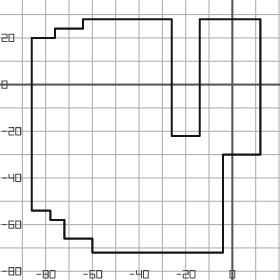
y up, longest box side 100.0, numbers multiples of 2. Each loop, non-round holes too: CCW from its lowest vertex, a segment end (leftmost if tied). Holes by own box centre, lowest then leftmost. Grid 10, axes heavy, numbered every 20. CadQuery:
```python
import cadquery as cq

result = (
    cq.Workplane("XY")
    .moveTo(-60.0, -72.0)
    .lineTo(-4.0, -72.0)
    .lineTo(-4.0, -30.0)
    .lineTo(12.0, -30.0)
    .lineTo(12.0, 28.0)
    .lineTo(-14.0, 28.0)
    .lineTo(-14.0, -22.0)
    .lineTo(-26.0, -22.0)
    .lineTo(-26.0, 28.0)
    .lineTo(-64.0, 28.0)
    .lineTo(-64.0, 24.0)
    .lineTo(-76.0, 24.0)
    .lineTo(-76.0, 20.0)
    .lineTo(-86.0, 20.0)
    .lineTo(-86.0, -54.0)
    .lineTo(-78.0, -54.0)
    .lineTo(-78.0, -58.0)
    .lineTo(-72.0, -58.0)
    .lineTo(-72.0, -66.0)
    .lineTo(-60.0, -66.0)
    .close()
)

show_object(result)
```